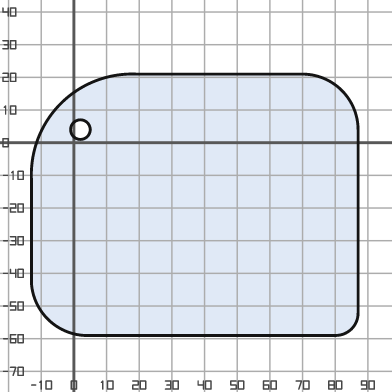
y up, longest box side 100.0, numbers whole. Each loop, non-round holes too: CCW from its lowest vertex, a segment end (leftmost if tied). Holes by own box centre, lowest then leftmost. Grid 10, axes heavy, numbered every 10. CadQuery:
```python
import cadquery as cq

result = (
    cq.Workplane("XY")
    .moveTo(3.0, -59.0)
    .lineTo(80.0, -59.0)
    .threePointArc((85.0, -57.0), (87.0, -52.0))
    .lineTo(87.0, 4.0)
    .threePointArc((82.0, 16.0), (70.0, 21.0))
    .lineTo(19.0, 21.0)
    .threePointArc((-4.0, 12.0), (-13.0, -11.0))
    .lineTo(-13.0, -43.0)
    .threePointArc((-8.0, -54.0), (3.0, -59.0))
    .close()
    .moveTo(2.0, 4.0)
    .circle(3.0)
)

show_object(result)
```